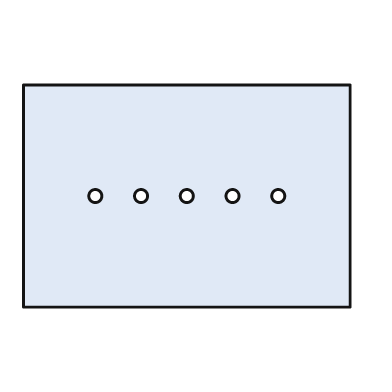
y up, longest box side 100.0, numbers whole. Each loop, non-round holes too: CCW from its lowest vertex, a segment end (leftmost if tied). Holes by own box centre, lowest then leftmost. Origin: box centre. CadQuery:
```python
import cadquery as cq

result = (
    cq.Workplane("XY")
    .moveTo(-50.0, -34.0)
    .lineTo(50.0, -34.0)
    .lineTo(50.0, 34.0)
    .lineTo(-50.0, 34.0)
    .close()
    .moveTo(-28.0, 0.0)
    .circle(2.0)
    .moveTo(-14.0, 0.0)
    .circle(2.0)
    .moveTo(0.0, 0.0)
    .circle(2.0)
    .moveTo(14.0, 0.0)
    .circle(2.0)
    .moveTo(28.0, 0.0)
    .circle(2.0)
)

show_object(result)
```